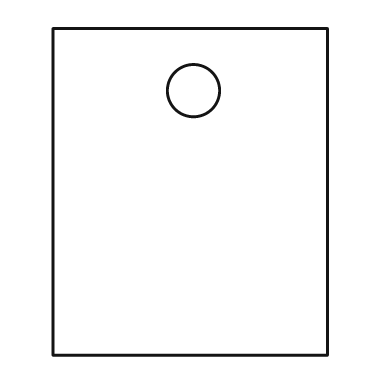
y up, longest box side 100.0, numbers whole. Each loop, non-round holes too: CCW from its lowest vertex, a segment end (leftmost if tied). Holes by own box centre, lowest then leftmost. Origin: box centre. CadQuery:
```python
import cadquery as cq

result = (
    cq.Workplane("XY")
    .moveTo(-42.0, -50.0)
    .lineTo(42.0, -50.0)
    .lineTo(42.0, 50.0)
    .lineTo(-42.0, 50.0)
    .close()
    .moveTo(1.0, 31.0)
    .circle(8.0)
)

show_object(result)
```